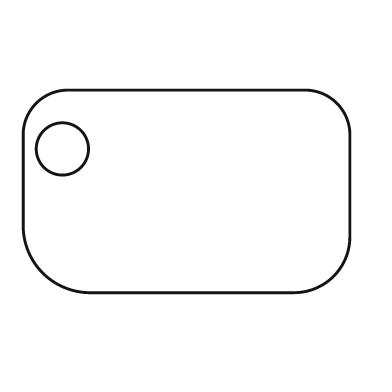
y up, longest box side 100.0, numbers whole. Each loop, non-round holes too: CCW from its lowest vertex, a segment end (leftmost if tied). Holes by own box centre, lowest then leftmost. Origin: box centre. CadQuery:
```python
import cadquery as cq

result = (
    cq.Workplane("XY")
    .moveTo(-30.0, -31.0)
    .lineTo(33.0, -31.0)
    .threePointArc((45.0, -26.0), (50.0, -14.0))
    .lineTo(50.0, 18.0)
    .threePointArc((46.0, 27.0), (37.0, 31.0))
    .lineTo(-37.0, 31.0)
    .threePointArc((-46.0, 27.0), (-50.0, 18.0))
    .lineTo(-50.0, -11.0)
    .threePointArc((-44.0, -25.0), (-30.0, -31.0))
    .close()
    .moveTo(-38.0, 13.0)
    .circle(8.0)
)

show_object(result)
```